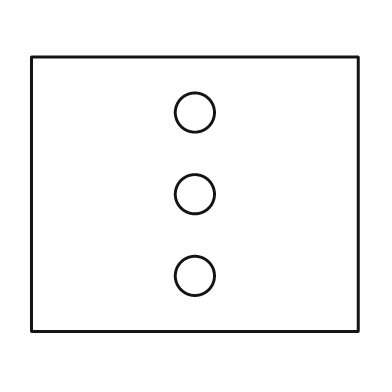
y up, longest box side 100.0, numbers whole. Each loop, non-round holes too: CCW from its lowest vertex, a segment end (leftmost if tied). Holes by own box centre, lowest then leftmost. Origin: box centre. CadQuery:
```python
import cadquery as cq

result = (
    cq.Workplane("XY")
    .moveTo(-50.0, -42.0)
    .lineTo(50.0, -42.0)
    .lineTo(50.0, 42.0)
    .lineTo(-50.0, 42.0)
    .close()
    .moveTo(0.0, -25.0)
    .circle(6.0)
    .moveTo(0.0, 0.0)
    .circle(6.0)
    .moveTo(0.0, 25.0)
    .circle(6.0)
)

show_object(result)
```